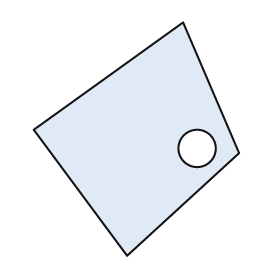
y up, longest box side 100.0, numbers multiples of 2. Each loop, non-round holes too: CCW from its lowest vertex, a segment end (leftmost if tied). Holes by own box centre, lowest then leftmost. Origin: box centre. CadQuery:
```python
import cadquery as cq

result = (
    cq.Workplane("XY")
    .moveTo(-4.0, -50.0)
    .lineTo(44.0, -6.0)
    .lineTo(20.0, 50.0)
    .lineTo(-44.0, 4.0)
    .close()
    .moveTo(26.0, -4.0)
    .circle(8.0)
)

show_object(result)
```